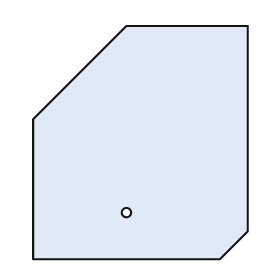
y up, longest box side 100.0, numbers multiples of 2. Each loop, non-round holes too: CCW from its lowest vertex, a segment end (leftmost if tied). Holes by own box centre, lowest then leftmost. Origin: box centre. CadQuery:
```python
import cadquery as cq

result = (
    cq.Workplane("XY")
    .moveTo(-46.0, -50.0)
    .lineTo(34.0, -50.0)
    .lineTo(46.0, -38.0)
    .lineTo(46.0, 50.0)
    .lineTo(-6.0, 50.0)
    .lineTo(-46.0, 10.0)
    .close()
    .moveTo(-6.0, -30.0)
    .circle(2.0)
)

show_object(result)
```